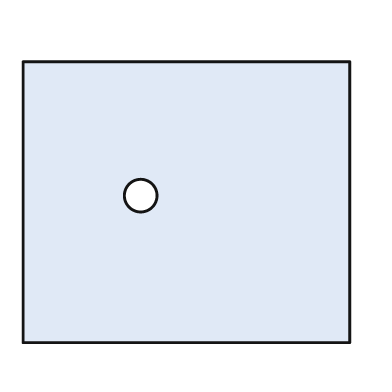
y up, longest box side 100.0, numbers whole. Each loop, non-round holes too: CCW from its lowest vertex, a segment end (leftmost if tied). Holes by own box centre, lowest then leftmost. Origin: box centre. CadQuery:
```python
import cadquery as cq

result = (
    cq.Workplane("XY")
    .moveTo(-50.0, -43.0)
    .lineTo(50.0, -43.0)
    .lineTo(50.0, 43.0)
    .lineTo(-50.0, 43.0)
    .close()
    .moveTo(-14.0, 2.0)
    .circle(5.0)
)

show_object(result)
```